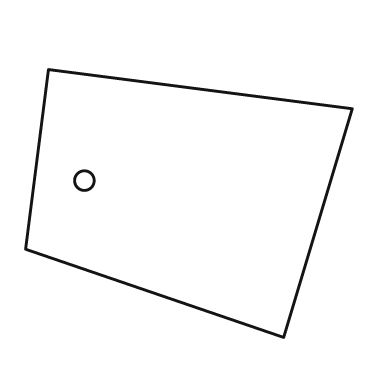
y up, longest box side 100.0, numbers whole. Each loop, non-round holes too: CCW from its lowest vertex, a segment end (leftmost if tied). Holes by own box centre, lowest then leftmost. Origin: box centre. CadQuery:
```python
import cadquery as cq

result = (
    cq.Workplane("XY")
    .moveTo(29.0, -41.0)
    .lineTo(50.0, 29.0)
    .lineTo(-43.0, 41.0)
    .lineTo(-50.0, -14.0)
    .close()
    .moveTo(-32.0, 7.0)
    .circle(3.0)
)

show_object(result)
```